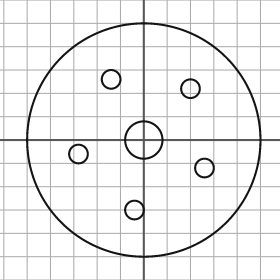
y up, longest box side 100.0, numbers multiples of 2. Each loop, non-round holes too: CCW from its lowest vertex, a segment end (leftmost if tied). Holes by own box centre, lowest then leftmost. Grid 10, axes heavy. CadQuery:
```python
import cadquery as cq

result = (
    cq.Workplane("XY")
    .moveTo(0.0, 0.0)
    .circle(50.0)
    .moveTo(-4.0, -30.0)
    .circle(4.0)
    .moveTo(26.0, -12.0)
    .circle(4.0)
    .moveTo(-28.0, -6.0)
    .circle(4.0)
    .moveTo(0.0, 0.0)
    .circle(8.0)
    .moveTo(20.0, 22.0)
    .circle(4.0)
    .moveTo(-14.0, 26.0)
    .circle(4.0)
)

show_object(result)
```